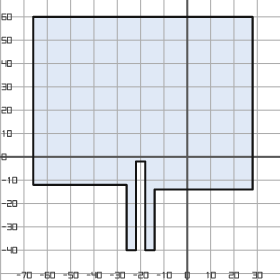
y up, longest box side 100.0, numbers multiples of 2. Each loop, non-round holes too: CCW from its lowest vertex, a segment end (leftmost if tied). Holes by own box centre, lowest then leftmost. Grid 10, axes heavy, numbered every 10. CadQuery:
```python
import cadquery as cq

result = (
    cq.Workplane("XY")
    .moveTo(-26.0, -40.0)
    .lineTo(-22.0, -40.0)
    .lineTo(-22.0, -2.0)
    .lineTo(-18.0, -2.0)
    .lineTo(-18.0, -40.0)
    .lineTo(-14.0, -40.0)
    .lineTo(-14.0, -14.0)
    .lineTo(28.0, -14.0)
    .lineTo(28.0, 60.0)
    .lineTo(-66.0, 60.0)
    .lineTo(-66.0, -12.0)
    .lineTo(-26.0, -12.0)
    .close()
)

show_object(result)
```